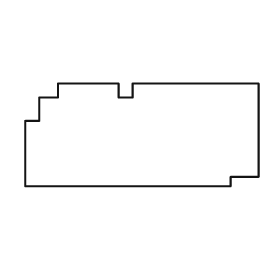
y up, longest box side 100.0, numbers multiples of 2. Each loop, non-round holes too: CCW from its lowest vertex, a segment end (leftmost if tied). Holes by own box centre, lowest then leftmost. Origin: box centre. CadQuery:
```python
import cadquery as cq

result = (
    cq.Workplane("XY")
    .moveTo(-50.0, -22.0)
    .lineTo(38.0, -22.0)
    .lineTo(38.0, -18.0)
    .lineTo(50.0, -18.0)
    .lineTo(50.0, 22.0)
    .lineTo(-4.0, 22.0)
    .lineTo(-4.0, 16.0)
    .lineTo(-10.0, 16.0)
    .lineTo(-10.0, 22.0)
    .lineTo(-36.0, 22.0)
    .lineTo(-36.0, 16.0)
    .lineTo(-44.0, 16.0)
    .lineTo(-44.0, 6.0)
    .lineTo(-50.0, 6.0)
    .close()
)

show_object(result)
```